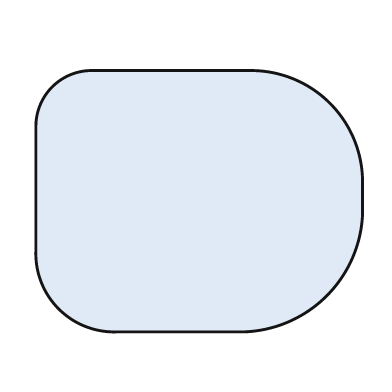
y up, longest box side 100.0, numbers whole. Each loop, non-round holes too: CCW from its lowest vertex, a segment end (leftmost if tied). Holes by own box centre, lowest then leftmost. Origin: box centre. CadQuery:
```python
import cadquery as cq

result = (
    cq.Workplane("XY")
    .moveTo(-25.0, -40.0)
    .lineTo(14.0, -40.0)
    .threePointArc((39.0, -29.0), (50.0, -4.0))
    .lineTo(50.0, 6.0)
    .threePointArc((40.0, 30.0), (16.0, 40.0))
    .lineTo(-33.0, 40.0)
    .threePointArc((-45.0, 35.0), (-50.0, 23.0))
    .lineTo(-50.0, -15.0)
    .threePointArc((-43.0, -33.0), (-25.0, -40.0))
    .close()
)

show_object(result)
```